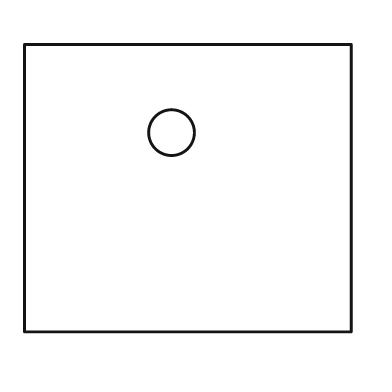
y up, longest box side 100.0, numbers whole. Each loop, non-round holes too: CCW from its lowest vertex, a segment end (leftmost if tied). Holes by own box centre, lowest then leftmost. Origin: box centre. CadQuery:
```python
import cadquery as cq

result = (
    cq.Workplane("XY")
    .moveTo(-50.0, -44.0)
    .lineTo(50.0, -44.0)
    .lineTo(50.0, 44.0)
    .lineTo(-50.0, 44.0)
    .close()
    .moveTo(-5.0, 17.0)
    .circle(7.0)
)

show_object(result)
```